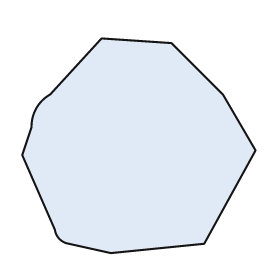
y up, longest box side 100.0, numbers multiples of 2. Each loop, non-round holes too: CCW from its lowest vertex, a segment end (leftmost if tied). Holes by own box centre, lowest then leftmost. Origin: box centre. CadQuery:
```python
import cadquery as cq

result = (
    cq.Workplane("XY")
    .moveTo(-12.0, -46.0)
    .lineTo(28.0, -42.0)
    .lineTo(50.0, -2.0)
    .lineTo(36.0, 22.0)
    .lineTo(14.0, 44.0)
    .lineTo(-16.0, 46.0)
    .lineTo(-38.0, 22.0)
    .threePointArc((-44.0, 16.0), (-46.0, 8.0))
    .lineTo(-50.0, -4.0)
    .lineTo(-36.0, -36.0)
    .threePointArc((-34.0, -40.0), (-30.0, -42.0))
    .close()
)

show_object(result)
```